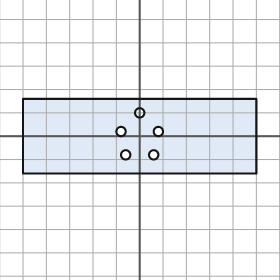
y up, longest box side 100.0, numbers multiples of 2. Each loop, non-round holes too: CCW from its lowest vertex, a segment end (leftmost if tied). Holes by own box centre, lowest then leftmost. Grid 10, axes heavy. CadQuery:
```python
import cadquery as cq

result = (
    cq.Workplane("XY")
    .moveTo(-50.0, -16.0)
    .lineTo(50.0, -16.0)
    .lineTo(50.0, 16.0)
    .lineTo(-50.0, 16.0)
    .close()
    .moveTo(-6.0, -8.0)
    .circle(2.0)
    .moveTo(6.0, -8.0)
    .circle(2.0)
    .moveTo(-8.0, 2.0)
    .circle(2.0)
    .moveTo(8.0, 2.0)
    .circle(2.0)
    .moveTo(0.0, 10.0)
    .circle(2.0)
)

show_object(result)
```